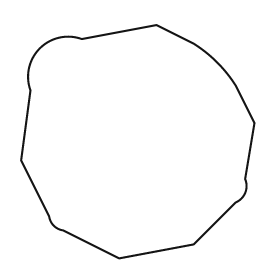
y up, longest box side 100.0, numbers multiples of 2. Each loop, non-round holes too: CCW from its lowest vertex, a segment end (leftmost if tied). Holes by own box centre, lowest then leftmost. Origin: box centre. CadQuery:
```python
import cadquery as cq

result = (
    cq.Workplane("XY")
    .moveTo(-8.0, -50.0)
    .lineTo(24.0, -44.0)
    .lineTo(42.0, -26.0)
    .threePointArc((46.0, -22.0), (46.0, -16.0))
    .lineTo(50.0, 8.0)
    .lineTo(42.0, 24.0)
    .threePointArc((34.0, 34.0), (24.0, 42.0))
    .lineTo(8.0, 50.0)
    .lineTo(-24.0, 44.0)
    .threePointArc((-42.0, 40.0), (-46.0, 22.0))
    .lineTo(-50.0, -8.0)
    .lineTo(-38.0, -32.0)
    .threePointArc((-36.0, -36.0), (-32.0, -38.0))
    .close()
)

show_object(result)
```